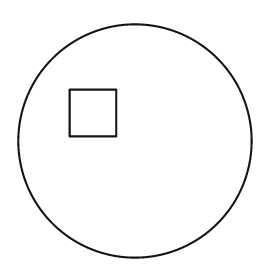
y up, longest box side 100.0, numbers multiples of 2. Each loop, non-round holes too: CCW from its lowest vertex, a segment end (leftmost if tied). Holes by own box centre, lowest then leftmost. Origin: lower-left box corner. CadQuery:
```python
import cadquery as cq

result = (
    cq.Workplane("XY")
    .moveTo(50.0, 50.0)
    .circle(50.0)
    .moveTo(22.0, 52.0)
    .lineTo(42.0, 52.0)
    .lineTo(42.0, 72.0)
    .lineTo(22.0, 72.0)
    .close()
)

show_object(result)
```